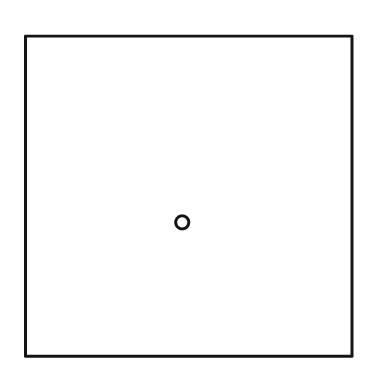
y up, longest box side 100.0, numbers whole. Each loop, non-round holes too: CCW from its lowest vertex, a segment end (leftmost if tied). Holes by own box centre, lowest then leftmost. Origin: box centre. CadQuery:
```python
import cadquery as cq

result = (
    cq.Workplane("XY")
    .moveTo(-50.0, -49.0)
    .lineTo(50.0, -49.0)
    .lineTo(50.0, 49.0)
    .lineTo(-50.0, 49.0)
    .close()
    .moveTo(-2.0, -8.0)
    .circle(2.0)
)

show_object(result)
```